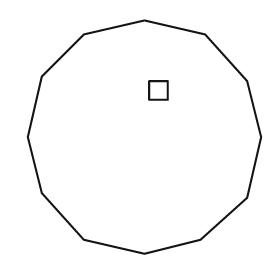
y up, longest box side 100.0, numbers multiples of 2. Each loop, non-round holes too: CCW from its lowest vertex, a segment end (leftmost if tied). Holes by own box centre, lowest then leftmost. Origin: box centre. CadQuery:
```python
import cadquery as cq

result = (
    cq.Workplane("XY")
    .moveTo(0.0, -50.0)
    .lineTo(24.0, -44.0)
    .lineTo(44.0, -26.0)
    .lineTo(50.0, 0.0)
    .lineTo(44.0, 24.0)
    .lineTo(26.0, 44.0)
    .lineTo(0.0, 50.0)
    .lineTo(-26.0, 44.0)
    .lineTo(-44.0, 26.0)
    .lineTo(-50.0, 0.0)
    .lineTo(-44.0, -24.0)
    .lineTo(-26.0, -44.0)
    .close()
    .moveTo(2.0, 16.0)
    .lineTo(10.0, 16.0)
    .lineTo(10.0, 24.0)
    .lineTo(2.0, 24.0)
    .close()
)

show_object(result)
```